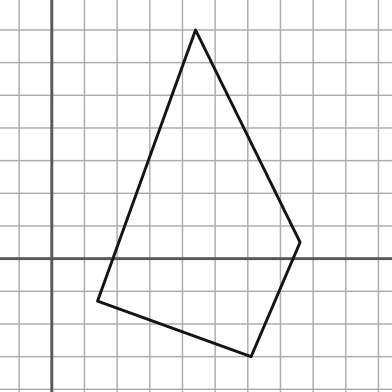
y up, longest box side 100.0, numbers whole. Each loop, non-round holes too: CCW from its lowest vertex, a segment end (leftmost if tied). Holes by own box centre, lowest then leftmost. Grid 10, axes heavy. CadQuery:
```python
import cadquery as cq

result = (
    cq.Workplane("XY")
    .moveTo(61.0, -30.0)
    .lineTo(76.0, 5.0)
    .lineTo(44.0, 70.0)
    .lineTo(14.0, -13.0)
    .close()
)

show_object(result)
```